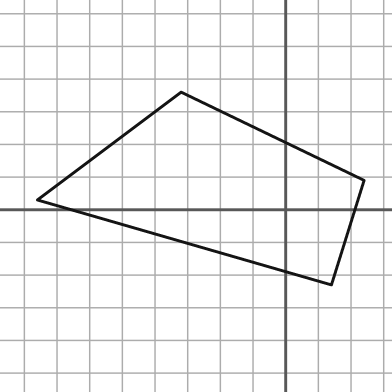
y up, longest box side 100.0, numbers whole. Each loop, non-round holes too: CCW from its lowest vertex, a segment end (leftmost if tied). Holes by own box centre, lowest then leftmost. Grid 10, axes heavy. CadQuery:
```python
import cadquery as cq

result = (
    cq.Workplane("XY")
    .moveTo(14.0, -23.0)
    .lineTo(24.0, 9.0)
    .lineTo(-32.0, 36.0)
    .lineTo(-76.0, 3.0)
    .close()
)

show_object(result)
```